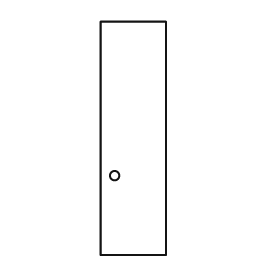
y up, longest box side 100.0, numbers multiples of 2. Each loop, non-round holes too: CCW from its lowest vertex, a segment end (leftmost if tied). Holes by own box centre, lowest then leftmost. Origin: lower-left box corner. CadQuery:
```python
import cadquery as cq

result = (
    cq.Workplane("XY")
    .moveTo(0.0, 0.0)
    .lineTo(28.0, 0.0)
    .lineTo(28.0, 100.0)
    .lineTo(0.0, 100.0)
    .close()
    .moveTo(6.0, 34.0)
    .circle(2.0)
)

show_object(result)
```